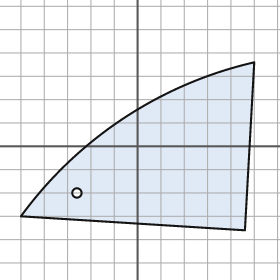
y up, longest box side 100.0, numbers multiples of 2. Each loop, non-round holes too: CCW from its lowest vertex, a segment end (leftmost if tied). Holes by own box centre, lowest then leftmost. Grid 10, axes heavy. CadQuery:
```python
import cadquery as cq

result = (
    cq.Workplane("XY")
    .moveTo(46.0, -36.0)
    .lineTo(50.0, 36.0)
    .threePointArc((-6.0, 12.0), (-50.0, -30.0))
    .close()
    .moveTo(-26.0, -20.0)
    .circle(2.0)
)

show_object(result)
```